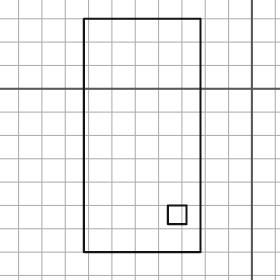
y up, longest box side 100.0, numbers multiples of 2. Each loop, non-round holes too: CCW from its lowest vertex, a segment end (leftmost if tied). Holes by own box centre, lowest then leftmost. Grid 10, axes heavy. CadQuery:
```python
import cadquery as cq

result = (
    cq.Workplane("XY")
    .moveTo(-72.0, -70.0)
    .lineTo(-22.0, -70.0)
    .lineTo(-22.0, 30.0)
    .lineTo(-72.0, 30.0)
    .close()
    .moveTo(-36.0, -58.0)
    .lineTo(-28.0, -58.0)
    .lineTo(-28.0, -50.0)
    .lineTo(-36.0, -50.0)
    .close()
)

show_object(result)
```